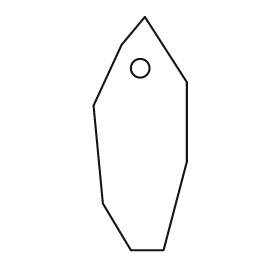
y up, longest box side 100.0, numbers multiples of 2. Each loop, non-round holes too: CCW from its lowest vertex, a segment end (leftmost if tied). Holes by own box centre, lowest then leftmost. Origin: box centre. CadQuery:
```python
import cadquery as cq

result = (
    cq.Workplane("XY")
    .moveTo(-4.0, -50.0)
    .lineTo(10.0, -50.0)
    .lineTo(20.0, -12.0)
    .lineTo(20.0, 22.0)
    .lineTo(2.0, 50.0)
    .lineTo(-8.0, 38.0)
    .lineTo(-20.0, 12.0)
    .lineTo(-16.0, -30.0)
    .close()
    .moveTo(0.0, 28.0)
    .circle(4.0)
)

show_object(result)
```